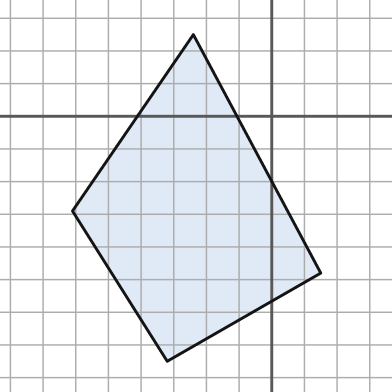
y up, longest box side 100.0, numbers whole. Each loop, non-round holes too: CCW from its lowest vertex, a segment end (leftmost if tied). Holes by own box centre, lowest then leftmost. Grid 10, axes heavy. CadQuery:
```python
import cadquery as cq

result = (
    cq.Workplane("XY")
    .moveTo(-32.0, -75.0)
    .lineTo(15.0, -48.0)
    .lineTo(-24.0, 25.0)
    .lineTo(-61.0, -29.0)
    .close()
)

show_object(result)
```